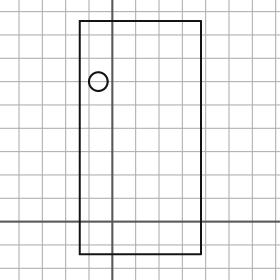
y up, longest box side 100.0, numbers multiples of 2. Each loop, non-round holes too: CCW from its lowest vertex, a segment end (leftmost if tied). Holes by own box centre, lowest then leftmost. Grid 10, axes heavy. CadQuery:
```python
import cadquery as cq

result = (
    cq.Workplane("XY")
    .moveTo(-14.0, -14.0)
    .lineTo(38.0, -14.0)
    .lineTo(38.0, 86.0)
    .lineTo(-14.0, 86.0)
    .close()
    .moveTo(-6.0, 60.0)
    .circle(4.0)
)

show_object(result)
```